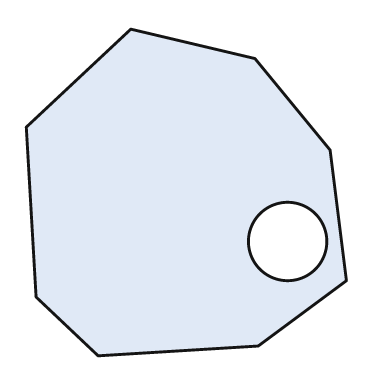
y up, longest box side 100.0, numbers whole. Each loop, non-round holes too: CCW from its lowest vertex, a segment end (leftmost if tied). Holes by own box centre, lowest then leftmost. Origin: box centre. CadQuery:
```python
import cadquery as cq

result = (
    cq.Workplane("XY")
    .moveTo(-27.0, -50.0)
    .lineTo(22.0, -47.0)
    .lineTo(49.0, -27.0)
    .lineTo(44.0, 13.0)
    .lineTo(21.0, 41.0)
    .lineTo(-17.0, 50.0)
    .lineTo(-49.0, 20.0)
    .lineTo(-46.0, -32.0)
    .close()
    .moveTo(31.0, -15.0)
    .circle(12.0)
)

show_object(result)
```